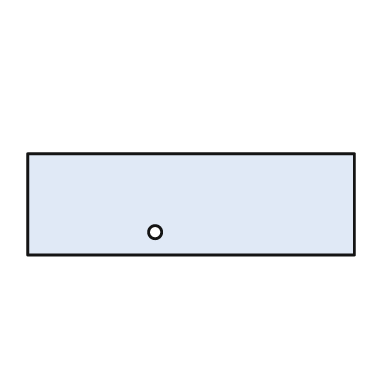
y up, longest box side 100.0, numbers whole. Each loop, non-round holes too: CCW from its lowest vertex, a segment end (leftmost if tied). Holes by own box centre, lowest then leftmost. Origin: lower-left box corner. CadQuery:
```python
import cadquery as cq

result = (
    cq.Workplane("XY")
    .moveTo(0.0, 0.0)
    .lineTo(100.0, 0.0)
    .lineTo(100.0, 31.0)
    .lineTo(0.0, 31.0)
    .close()
    .moveTo(39.0, 7.0)
    .circle(2.0)
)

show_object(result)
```